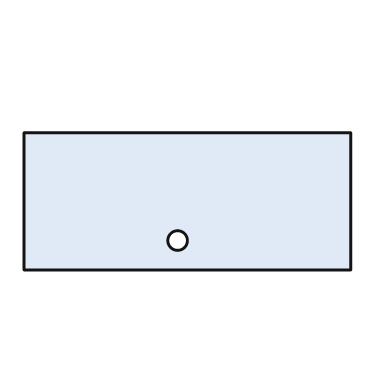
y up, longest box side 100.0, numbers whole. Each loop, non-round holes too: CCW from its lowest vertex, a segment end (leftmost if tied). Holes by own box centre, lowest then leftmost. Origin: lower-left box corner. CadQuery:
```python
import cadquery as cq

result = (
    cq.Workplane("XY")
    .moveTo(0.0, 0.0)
    .lineTo(100.0, 0.0)
    .lineTo(100.0, 42.0)
    .lineTo(0.0, 42.0)
    .close()
    .moveTo(47.0, 9.0)
    .circle(3.0)
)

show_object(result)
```